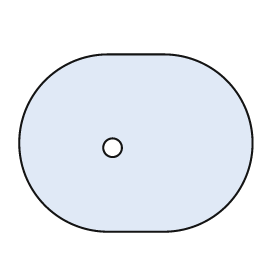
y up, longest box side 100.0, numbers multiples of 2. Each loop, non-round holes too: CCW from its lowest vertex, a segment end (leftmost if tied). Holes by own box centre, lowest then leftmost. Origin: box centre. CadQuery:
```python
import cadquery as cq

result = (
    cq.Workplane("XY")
    .moveTo(-12.0, -38.0)
    .lineTo(12.0, -38.0)
    .threePointArc((50.0, 0.0), (12.0, 38.0))
    .lineTo(-12.0, 38.0)
    .threePointArc((-50.0, 0.0), (-12.0, -38.0))
    .close()
    .moveTo(-10.0, -2.0)
    .circle(4.0)
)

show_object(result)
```